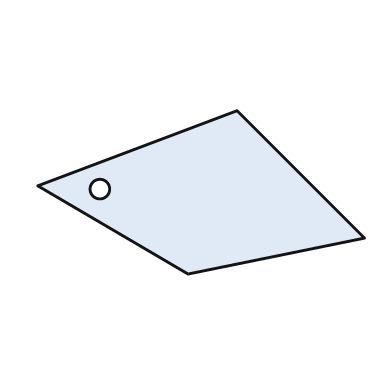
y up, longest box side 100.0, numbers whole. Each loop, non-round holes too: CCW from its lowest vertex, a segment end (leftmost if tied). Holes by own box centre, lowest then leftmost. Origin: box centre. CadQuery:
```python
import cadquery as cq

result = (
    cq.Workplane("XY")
    .moveTo(-4.0, -25.0)
    .lineTo(50.0, -14.0)
    .lineTo(11.0, 25.0)
    .lineTo(-50.0, 2.0)
    .close()
    .moveTo(-31.0, 1.0)
    .circle(3.0)
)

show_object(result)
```